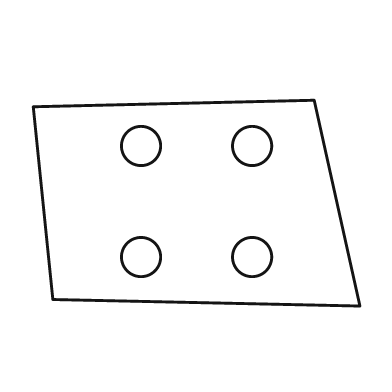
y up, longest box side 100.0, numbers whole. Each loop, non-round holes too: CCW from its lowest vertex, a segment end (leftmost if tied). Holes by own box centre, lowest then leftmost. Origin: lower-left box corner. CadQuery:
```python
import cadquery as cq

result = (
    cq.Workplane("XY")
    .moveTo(100.0, 0.0)
    .lineTo(86.0, 63.0)
    .lineTo(0.0, 61.0)
    .lineTo(6.0, 2.0)
    .close()
    .moveTo(33.0, 15.0)
    .circle(6.0)
    .moveTo(67.0, 15.0)
    .circle(6.0)
    .moveTo(33.0, 49.0)
    .circle(6.0)
    .moveTo(67.0, 49.0)
    .circle(6.0)
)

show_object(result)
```